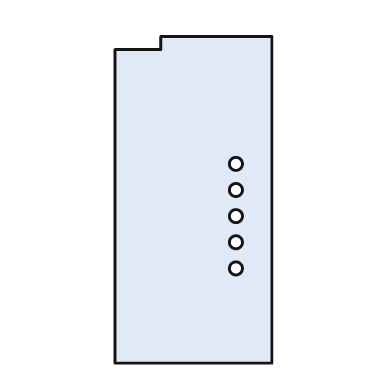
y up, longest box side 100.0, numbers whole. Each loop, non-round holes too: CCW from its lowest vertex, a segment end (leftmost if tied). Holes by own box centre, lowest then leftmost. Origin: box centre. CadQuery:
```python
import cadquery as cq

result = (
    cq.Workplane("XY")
    .moveTo(-24.0, -50.0)
    .lineTo(24.0, -50.0)
    .lineTo(24.0, 50.0)
    .lineTo(-10.0, 50.0)
    .lineTo(-10.0, 46.0)
    .lineTo(-24.0, 46.0)
    .close()
    .moveTo(13.0, -21.0)
    .circle(2.0)
    .moveTo(13.0, -13.0)
    .circle(2.0)
    .moveTo(13.0, -5.0)
    .circle(2.0)
    .moveTo(13.0, 3.0)
    .circle(2.0)
    .moveTo(13.0, 11.0)
    .circle(2.0)
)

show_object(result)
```